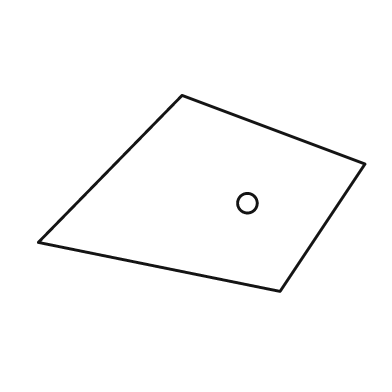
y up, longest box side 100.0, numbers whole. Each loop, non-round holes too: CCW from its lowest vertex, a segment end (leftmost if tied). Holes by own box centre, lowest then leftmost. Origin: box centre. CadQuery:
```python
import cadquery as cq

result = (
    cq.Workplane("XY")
    .moveTo(24.0, -30.0)
    .lineTo(50.0, 9.0)
    .lineTo(-6.0, 30.0)
    .lineTo(-50.0, -15.0)
    .close()
    .moveTo(14.0, -3.0)
    .circle(3.0)
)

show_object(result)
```